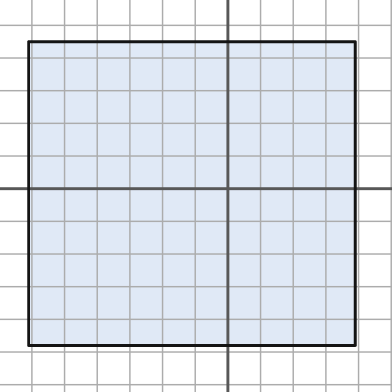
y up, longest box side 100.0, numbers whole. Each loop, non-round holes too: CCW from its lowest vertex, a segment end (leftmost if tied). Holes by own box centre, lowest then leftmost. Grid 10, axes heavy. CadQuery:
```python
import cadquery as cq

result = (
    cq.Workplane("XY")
    .moveTo(-61.0, -48.0)
    .lineTo(39.0, -48.0)
    .lineTo(39.0, 45.0)
    .lineTo(-61.0, 45.0)
    .close()
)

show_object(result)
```